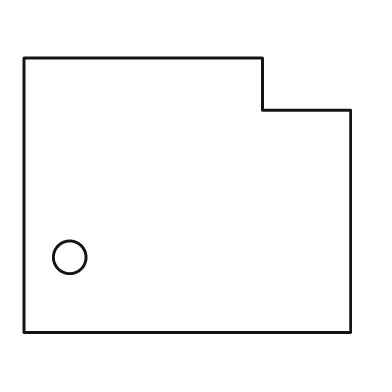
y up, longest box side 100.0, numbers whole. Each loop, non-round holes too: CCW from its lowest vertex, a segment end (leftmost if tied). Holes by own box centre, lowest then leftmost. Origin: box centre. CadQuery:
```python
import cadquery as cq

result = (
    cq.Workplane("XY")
    .moveTo(-50.0, -42.0)
    .lineTo(50.0, -42.0)
    .lineTo(50.0, 26.0)
    .lineTo(23.0, 26.0)
    .lineTo(23.0, 42.0)
    .lineTo(-50.0, 42.0)
    .close()
    .moveTo(-36.0, -19.0)
    .circle(5.0)
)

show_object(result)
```